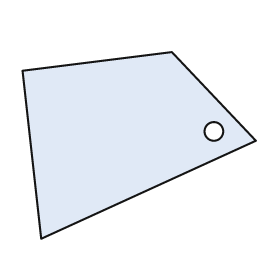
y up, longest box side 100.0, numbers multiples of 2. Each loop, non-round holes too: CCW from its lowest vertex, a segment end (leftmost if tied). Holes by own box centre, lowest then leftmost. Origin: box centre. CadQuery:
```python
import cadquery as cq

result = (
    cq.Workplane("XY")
    .moveTo(-42.0, -40.0)
    .lineTo(50.0, 2.0)
    .lineTo(14.0, 40.0)
    .lineTo(-50.0, 32.0)
    .close()
    .moveTo(32.0, 6.0)
    .circle(4.0)
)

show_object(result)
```